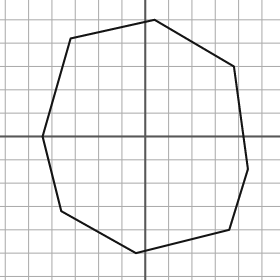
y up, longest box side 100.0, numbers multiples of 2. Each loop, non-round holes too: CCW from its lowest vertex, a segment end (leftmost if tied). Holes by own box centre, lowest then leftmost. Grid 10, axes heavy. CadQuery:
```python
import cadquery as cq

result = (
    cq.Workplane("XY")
    .moveTo(-4.0, -50.0)
    .lineTo(36.0, -40.0)
    .lineTo(44.0, -14.0)
    .lineTo(38.0, 30.0)
    .lineTo(4.0, 50.0)
    .lineTo(-32.0, 42.0)
    .lineTo(-44.0, 0.0)
    .lineTo(-36.0, -32.0)
    .close()
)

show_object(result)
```